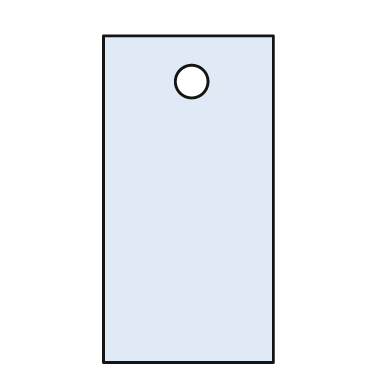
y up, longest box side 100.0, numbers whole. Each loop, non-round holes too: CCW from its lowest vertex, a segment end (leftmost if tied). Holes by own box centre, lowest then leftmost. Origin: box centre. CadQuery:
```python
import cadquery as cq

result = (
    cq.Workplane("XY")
    .moveTo(-26.0, -50.0)
    .lineTo(26.0, -50.0)
    .lineTo(26.0, 50.0)
    .lineTo(-26.0, 50.0)
    .close()
    .moveTo(1.0, 36.0)
    .circle(5.0)
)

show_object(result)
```